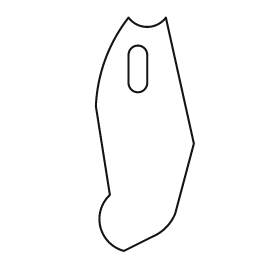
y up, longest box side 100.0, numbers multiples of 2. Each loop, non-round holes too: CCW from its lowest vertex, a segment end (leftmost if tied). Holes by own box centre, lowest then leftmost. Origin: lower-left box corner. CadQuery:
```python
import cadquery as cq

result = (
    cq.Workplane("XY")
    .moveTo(12.0, 0.0)
    .lineTo(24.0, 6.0)
    .threePointArc((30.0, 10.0), (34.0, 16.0))
    .lineTo(42.0, 46.0)
    .lineTo(30.0, 100.0)
    .threePointArc((22.0, 96.0), (14.0, 100.0))
    .threePointArc((4.0, 82.0), (0.0, 62.0))
    .lineTo(6.0, 24.0)
    .threePointArc((2.0, 10.0), (12.0, 0.0))
    .close()
    .moveTo(14.0, 72.0)
    .threePointArc((18.0, 68.0), (22.0, 72.0))
    .lineTo(22.0, 84.0)
    .threePointArc((18.0, 88.0), (14.0, 84.0))
    .close()
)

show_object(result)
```